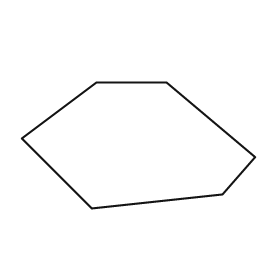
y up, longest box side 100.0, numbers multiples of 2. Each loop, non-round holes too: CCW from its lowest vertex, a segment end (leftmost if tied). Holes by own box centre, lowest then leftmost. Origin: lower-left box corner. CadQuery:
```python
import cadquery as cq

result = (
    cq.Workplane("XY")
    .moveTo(30.0, 0.0)
    .lineTo(86.0, 6.0)
    .lineTo(100.0, 22.0)
    .lineTo(62.0, 54.0)
    .lineTo(32.0, 54.0)
    .lineTo(0.0, 30.0)
    .close()
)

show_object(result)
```